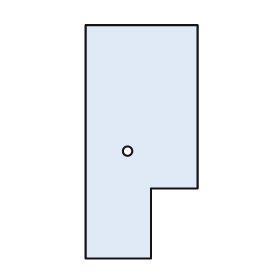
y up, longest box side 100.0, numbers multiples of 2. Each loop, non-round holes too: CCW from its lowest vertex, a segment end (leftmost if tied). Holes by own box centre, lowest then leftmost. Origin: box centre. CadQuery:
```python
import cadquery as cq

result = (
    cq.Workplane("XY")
    .moveTo(-24.0, -50.0)
    .lineTo(4.0, -50.0)
    .lineTo(4.0, -20.0)
    .lineTo(24.0, -20.0)
    .lineTo(24.0, 50.0)
    .lineTo(-24.0, 50.0)
    .close()
    .moveTo(-6.0, -4.0)
    .circle(2.0)
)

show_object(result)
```